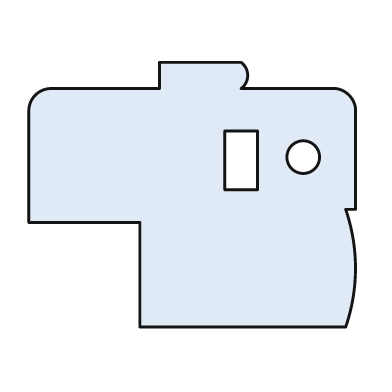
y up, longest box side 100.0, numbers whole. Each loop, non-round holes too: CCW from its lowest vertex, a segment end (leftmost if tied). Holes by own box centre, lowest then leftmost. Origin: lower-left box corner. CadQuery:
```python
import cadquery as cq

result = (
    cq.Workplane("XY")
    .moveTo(34.0, 0.0)
    .lineTo(97.0, 0.0)
    .threePointArc((100.0, 18.0), (97.0, 36.0))
    .lineTo(100.0, 36.0)
    .lineTo(100.0, 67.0)
    .threePointArc((98.0, 71.0), (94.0, 73.0))
    .lineTo(65.0, 73.0)
    .threePointArc((67.0, 77.0), (65.0, 81.0))
    .lineTo(40.0, 81.0)
    .lineTo(40.0, 73.0)
    .lineTo(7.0, 73.0)
    .threePointArc((2.0, 71.0), (0.0, 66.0))
    .lineTo(0.0, 32.0)
    .lineTo(34.0, 32.0)
    .close()
    .moveTo(60.0, 42.0)
    .lineTo(70.0, 42.0)
    .lineTo(70.0, 60.0)
    .lineTo(60.0, 60.0)
    .close()
    .moveTo(84.0, 52.0)
    .circle(5.0)
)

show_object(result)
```